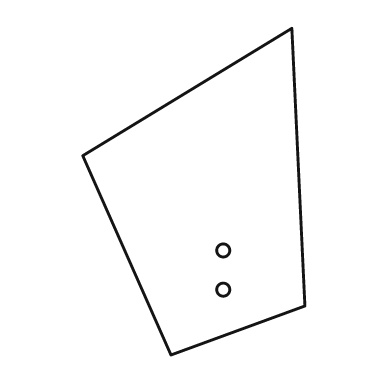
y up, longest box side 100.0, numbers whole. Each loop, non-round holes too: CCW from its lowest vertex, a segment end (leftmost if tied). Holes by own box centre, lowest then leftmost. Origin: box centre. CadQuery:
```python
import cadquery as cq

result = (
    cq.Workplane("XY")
    .moveTo(-7.0, -50.0)
    .lineTo(34.0, -35.0)
    .lineTo(30.0, 50.0)
    .lineTo(-34.0, 11.0)
    .close()
    .moveTo(9.0, -30.0)
    .circle(2.0)
    .moveTo(9.0, -18.0)
    .circle(2.0)
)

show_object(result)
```